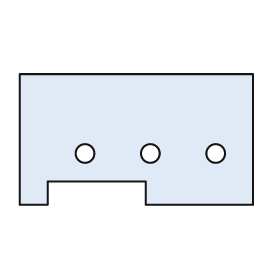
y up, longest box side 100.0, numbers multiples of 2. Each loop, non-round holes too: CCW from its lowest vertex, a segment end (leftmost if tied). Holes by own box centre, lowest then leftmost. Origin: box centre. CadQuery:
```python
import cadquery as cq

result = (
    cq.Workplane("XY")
    .moveTo(-50.0, -28.0)
    .lineTo(-38.0, -28.0)
    .lineTo(-38.0, -18.0)
    .lineTo(4.0, -18.0)
    .lineTo(4.0, -28.0)
    .lineTo(50.0, -28.0)
    .lineTo(50.0, 28.0)
    .lineTo(-50.0, 28.0)
    .close()
    .moveTo(-22.0, -6.0)
    .circle(4.0)
    .moveTo(6.0, -6.0)
    .circle(4.0)
    .moveTo(34.0, -6.0)
    .circle(4.0)
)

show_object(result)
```